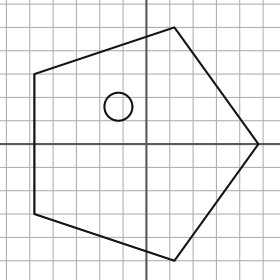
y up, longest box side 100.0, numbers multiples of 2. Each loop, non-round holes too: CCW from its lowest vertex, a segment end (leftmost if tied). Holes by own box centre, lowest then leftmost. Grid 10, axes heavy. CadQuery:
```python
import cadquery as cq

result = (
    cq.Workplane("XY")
    .moveTo(12.0, -50.0)
    .lineTo(48.0, 0.0)
    .lineTo(12.0, 50.0)
    .lineTo(-48.0, 30.0)
    .lineTo(-48.0, -30.0)
    .close()
    .moveTo(-12.0, 16.0)
    .circle(6.0)
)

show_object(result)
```